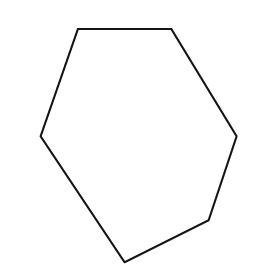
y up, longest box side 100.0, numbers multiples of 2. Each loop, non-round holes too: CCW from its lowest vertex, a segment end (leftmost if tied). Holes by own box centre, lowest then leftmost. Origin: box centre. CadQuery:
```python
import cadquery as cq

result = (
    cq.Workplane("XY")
    .moveTo(-6.0, -50.0)
    .lineTo(30.0, -32.0)
    .lineTo(42.0, 4.0)
    .lineTo(14.0, 50.0)
    .lineTo(-26.0, 50.0)
    .lineTo(-42.0, 4.0)
    .close()
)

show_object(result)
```